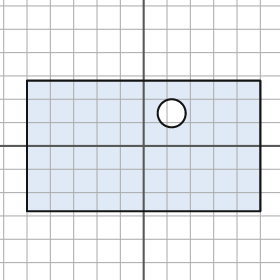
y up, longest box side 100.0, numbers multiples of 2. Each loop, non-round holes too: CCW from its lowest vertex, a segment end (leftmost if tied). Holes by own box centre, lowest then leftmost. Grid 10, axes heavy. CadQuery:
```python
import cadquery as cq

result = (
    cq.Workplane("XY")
    .moveTo(-50.0, -28.0)
    .lineTo(50.0, -28.0)
    .lineTo(50.0, 28.0)
    .lineTo(-50.0, 28.0)
    .close()
    .moveTo(12.0, 14.0)
    .circle(6.0)
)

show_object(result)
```